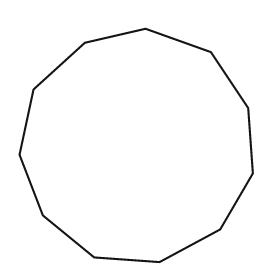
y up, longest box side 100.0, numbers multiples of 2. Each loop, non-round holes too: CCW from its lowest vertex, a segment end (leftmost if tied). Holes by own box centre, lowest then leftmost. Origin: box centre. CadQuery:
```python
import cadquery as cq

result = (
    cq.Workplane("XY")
    .moveTo(10.0, -50.0)
    .lineTo(36.0, -36.0)
    .lineTo(50.0, -12.0)
    .lineTo(48.0, 16.0)
    .lineTo(32.0, 40.0)
    .lineTo(4.0, 50.0)
    .lineTo(-22.0, 44.0)
    .lineTo(-44.0, 24.0)
    .lineTo(-50.0, -4.0)
    .lineTo(-40.0, -30.0)
    .lineTo(-18.0, -48.0)
    .close()
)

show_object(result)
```